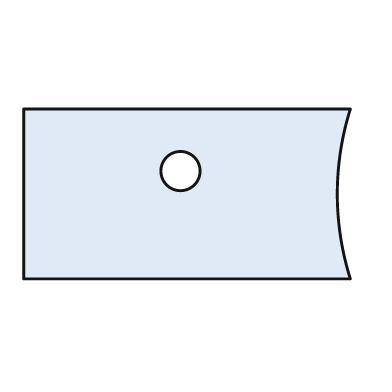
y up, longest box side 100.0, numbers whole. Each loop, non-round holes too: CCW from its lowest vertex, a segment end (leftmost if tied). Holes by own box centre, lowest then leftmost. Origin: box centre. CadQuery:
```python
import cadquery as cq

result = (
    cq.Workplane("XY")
    .moveTo(-50.0, -26.0)
    .lineTo(50.0, -26.0)
    .threePointArc((46.0, 0.0), (50.0, 26.0))
    .lineTo(-50.0, 26.0)
    .close()
    .moveTo(-2.0, 7.0)
    .circle(6.0)
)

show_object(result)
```